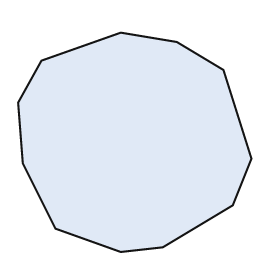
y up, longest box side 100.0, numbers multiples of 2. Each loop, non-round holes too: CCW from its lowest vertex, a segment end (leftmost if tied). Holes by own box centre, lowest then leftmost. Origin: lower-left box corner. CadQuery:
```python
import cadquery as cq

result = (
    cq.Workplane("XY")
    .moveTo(44.0, 0.0)
    .lineTo(62.0, 2.0)
    .lineTo(92.0, 20.0)
    .lineTo(100.0, 40.0)
    .lineTo(88.0, 78.0)
    .lineTo(68.0, 90.0)
    .lineTo(44.0, 94.0)
    .lineTo(10.0, 82.0)
    .lineTo(0.0, 64.0)
    .lineTo(2.0, 38.0)
    .lineTo(16.0, 10.0)
    .close()
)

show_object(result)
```